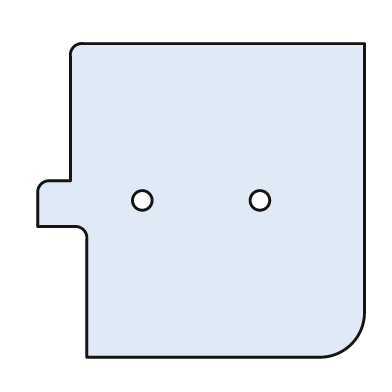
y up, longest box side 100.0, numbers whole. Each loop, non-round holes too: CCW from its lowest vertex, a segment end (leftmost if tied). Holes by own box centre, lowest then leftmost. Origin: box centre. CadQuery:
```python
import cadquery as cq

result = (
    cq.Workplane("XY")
    .moveTo(-35.0, -48.0)
    .lineTo(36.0, -48.0)
    .threePointArc((46.0, -44.0), (50.0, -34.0))
    .lineTo(50.0, 48.0)
    .lineTo(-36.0, 48.0)
    .threePointArc((-39.0, 47.0), (-40.0, 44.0))
    .lineTo(-40.0, 6.0)
    .lineTo(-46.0, 6.0)
    .threePointArc((-49.0, 5.0), (-50.0, 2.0))
    .lineTo(-50.0, -8.0)
    .lineTo(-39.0, -8.0)
    .threePointArc((-36.0, -9.0), (-35.0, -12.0))
    .close()
    .moveTo(-18.0, 0.0)
    .circle(3.0)
    .moveTo(18.0, 0.0)
    .circle(3.0)
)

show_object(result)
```